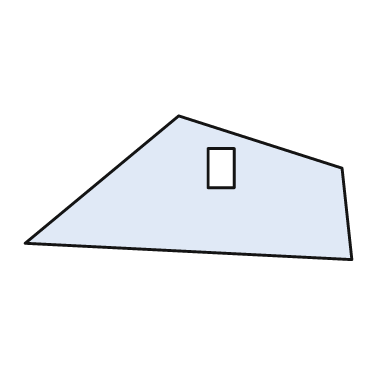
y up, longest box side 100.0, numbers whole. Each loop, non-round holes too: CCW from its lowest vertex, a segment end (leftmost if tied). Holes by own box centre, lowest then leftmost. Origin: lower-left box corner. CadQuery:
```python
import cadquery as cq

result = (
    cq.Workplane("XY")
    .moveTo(100.0, 0.0)
    .lineTo(97.0, 28.0)
    .lineTo(47.0, 44.0)
    .lineTo(0.0, 5.0)
    .close()
    .moveTo(56.0, 22.0)
    .lineTo(64.0, 22.0)
    .lineTo(64.0, 34.0)
    .lineTo(56.0, 34.0)
    .close()
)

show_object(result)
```